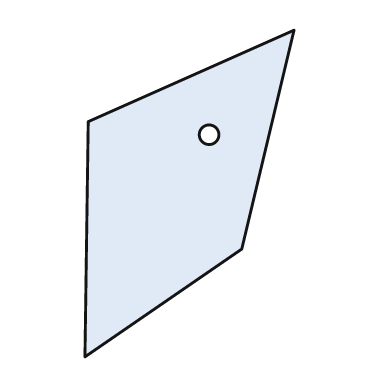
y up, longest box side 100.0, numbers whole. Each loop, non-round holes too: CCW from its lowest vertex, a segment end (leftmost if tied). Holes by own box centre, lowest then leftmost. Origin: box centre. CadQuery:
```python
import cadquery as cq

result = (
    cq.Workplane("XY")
    .moveTo(-32.0, -50.0)
    .lineTo(16.0, -17.0)
    .lineTo(32.0, 50.0)
    .lineTo(-31.0, 22.0)
    .close()
    .moveTo(6.0, 18.0)
    .circle(3.0)
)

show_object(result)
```